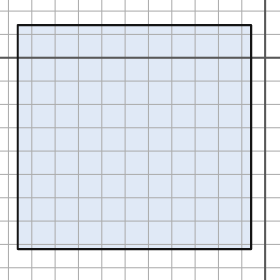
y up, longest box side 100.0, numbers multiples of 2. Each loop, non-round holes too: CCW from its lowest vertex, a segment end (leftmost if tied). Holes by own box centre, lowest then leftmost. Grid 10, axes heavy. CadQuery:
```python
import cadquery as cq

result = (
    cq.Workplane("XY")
    .moveTo(-106.0, -82.0)
    .lineTo(-6.0, -82.0)
    .lineTo(-6.0, 14.0)
    .lineTo(-106.0, 14.0)
    .close()
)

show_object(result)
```